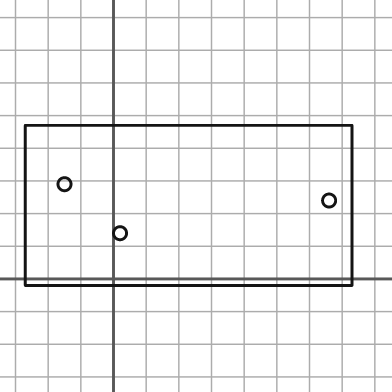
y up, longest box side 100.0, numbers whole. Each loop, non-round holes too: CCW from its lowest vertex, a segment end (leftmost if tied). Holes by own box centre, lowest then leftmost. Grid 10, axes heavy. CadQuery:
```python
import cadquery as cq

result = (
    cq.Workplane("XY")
    .moveTo(-27.0, -2.0)
    .lineTo(73.0, -2.0)
    .lineTo(73.0, 47.0)
    .lineTo(-27.0, 47.0)
    .close()
    .moveTo(2.0, 14.0)
    .circle(2.0)
    .moveTo(66.0, 24.0)
    .circle(2.0)
    .moveTo(-15.0, 29.0)
    .circle(2.0)
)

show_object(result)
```